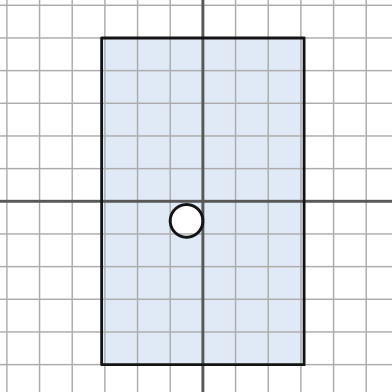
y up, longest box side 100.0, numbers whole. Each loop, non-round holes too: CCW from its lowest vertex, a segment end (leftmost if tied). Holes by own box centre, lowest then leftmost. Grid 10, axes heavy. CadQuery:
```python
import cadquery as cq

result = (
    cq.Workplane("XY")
    .moveTo(-31.0, -50.0)
    .lineTo(31.0, -50.0)
    .lineTo(31.0, 50.0)
    .lineTo(-31.0, 50.0)
    .close()
    .moveTo(-5.0, -6.0)
    .circle(5.0)
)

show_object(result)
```